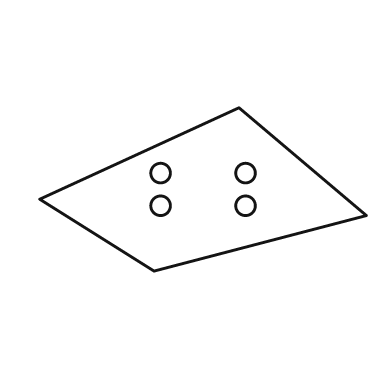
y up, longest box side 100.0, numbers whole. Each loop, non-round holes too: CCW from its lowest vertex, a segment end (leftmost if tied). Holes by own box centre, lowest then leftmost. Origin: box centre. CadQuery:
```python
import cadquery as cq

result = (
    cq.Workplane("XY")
    .moveTo(-15.0, -25.0)
    .lineTo(50.0, -8.0)
    .lineTo(11.0, 25.0)
    .lineTo(-50.0, -3.0)
    .close()
    .moveTo(-13.0, -5.0)
    .circle(3.0)
    .moveTo(13.0, -5.0)
    .circle(3.0)
    .moveTo(-13.0, 5.0)
    .circle(3.0)
    .moveTo(13.0, 5.0)
    .circle(3.0)
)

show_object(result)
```